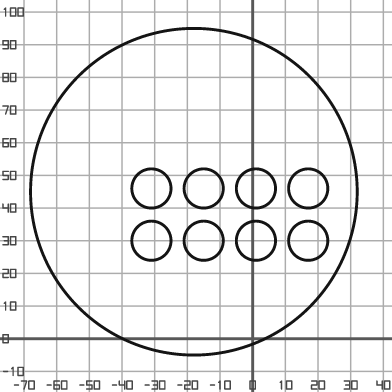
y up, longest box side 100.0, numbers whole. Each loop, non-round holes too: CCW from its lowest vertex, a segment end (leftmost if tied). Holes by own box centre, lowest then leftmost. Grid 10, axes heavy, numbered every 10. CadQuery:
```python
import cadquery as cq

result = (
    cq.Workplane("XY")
    .moveTo(-18.0, 45.0)
    .circle(50.0)
    .moveTo(-31.0, 30.0)
    .circle(6.0)
    .moveTo(-15.0, 30.0)
    .circle(6.0)
    .moveTo(1.0, 30.0)
    .circle(6.0)
    .moveTo(17.0, 30.0)
    .circle(6.0)
    .moveTo(-31.0, 46.0)
    .circle(6.0)
    .moveTo(-15.0, 46.0)
    .circle(6.0)
    .moveTo(1.0, 46.0)
    .circle(6.0)
    .moveTo(17.0, 46.0)
    .circle(6.0)
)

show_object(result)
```